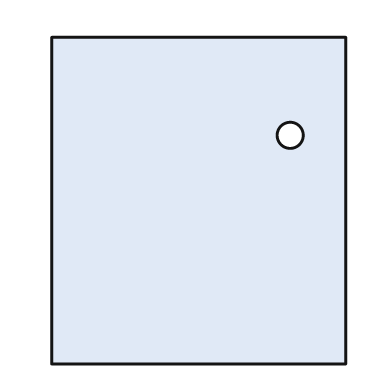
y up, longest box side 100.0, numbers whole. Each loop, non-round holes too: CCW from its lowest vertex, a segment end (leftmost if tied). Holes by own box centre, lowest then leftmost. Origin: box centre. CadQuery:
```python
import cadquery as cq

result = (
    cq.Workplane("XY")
    .moveTo(-45.0, -50.0)
    .lineTo(45.0, -50.0)
    .lineTo(45.0, 50.0)
    .lineTo(-45.0, 50.0)
    .close()
    .moveTo(28.0, 20.0)
    .circle(4.0)
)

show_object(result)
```